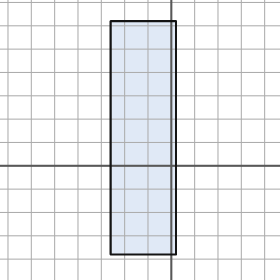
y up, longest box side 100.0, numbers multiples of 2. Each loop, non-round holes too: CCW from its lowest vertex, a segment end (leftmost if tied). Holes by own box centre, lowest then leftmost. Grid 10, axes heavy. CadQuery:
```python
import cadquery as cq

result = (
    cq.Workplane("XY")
    .moveTo(-26.0, -38.0)
    .lineTo(2.0, -38.0)
    .lineTo(2.0, 62.0)
    .lineTo(-26.0, 62.0)
    .close()
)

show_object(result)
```